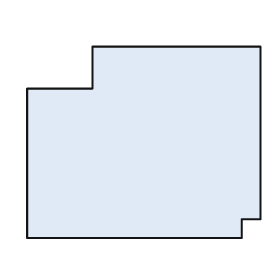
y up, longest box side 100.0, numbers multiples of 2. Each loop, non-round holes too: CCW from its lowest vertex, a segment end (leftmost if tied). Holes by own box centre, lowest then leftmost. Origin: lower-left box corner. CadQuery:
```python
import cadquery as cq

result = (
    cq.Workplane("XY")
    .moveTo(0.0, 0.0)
    .lineTo(92.0, 0.0)
    .lineTo(92.0, 8.0)
    .lineTo(100.0, 8.0)
    .lineTo(100.0, 82.0)
    .lineTo(28.0, 82.0)
    .lineTo(28.0, 64.0)
    .lineTo(0.0, 64.0)
    .close()
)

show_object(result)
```